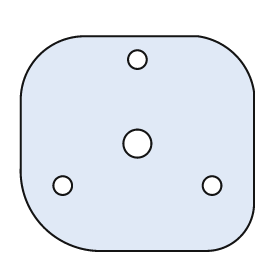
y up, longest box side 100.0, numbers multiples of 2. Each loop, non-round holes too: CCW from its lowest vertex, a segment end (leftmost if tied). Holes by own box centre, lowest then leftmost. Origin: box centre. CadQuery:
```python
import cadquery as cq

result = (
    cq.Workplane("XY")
    .moveTo(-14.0, -46.0)
    .lineTo(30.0, -46.0)
    .threePointArc((44.0, -40.0), (50.0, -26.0))
    .lineTo(50.0, 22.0)
    .threePointArc((42.0, 38.0), (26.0, 46.0))
    .lineTo(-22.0, 46.0)
    .threePointArc((-42.0, 38.0), (-50.0, 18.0))
    .lineTo(-50.0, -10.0)
    .threePointArc((-40.0, -36.0), (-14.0, -46.0))
    .close()
    .moveTo(-32.0, -18.0)
    .circle(4.0)
    .moveTo(32.0, -18.0)
    .circle(4.0)
    .moveTo(0.0, 0.0)
    .circle(6.0)
    .moveTo(0.0, 36.0)
    .circle(4.0)
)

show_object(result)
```